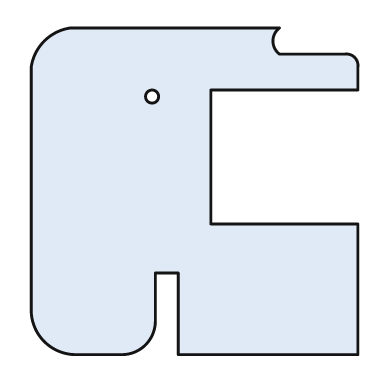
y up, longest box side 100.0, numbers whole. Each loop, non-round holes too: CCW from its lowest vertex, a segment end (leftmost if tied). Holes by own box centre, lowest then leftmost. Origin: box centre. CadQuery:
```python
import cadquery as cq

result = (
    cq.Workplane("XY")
    .moveTo(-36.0, -50.0)
    .lineTo(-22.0, -50.0)
    .threePointArc((-15.0, -47.0), (-12.0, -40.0))
    .lineTo(-12.0, -25.0)
    .lineTo(-5.0, -25.0)
    .lineTo(-5.0, -50.0)
    .lineTo(50.0, -50.0)
    .lineTo(50.0, -10.0)
    .lineTo(5.0, -10.0)
    .lineTo(5.0, 31.0)
    .lineTo(50.0, 31.0)
    .lineTo(50.0, 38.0)
    .threePointArc((49.0, 41.0), (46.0, 42.0))
    .lineTo(26.0, 42.0)
    .threePointArc((24.0, 46.0), (26.0, 50.0))
    .lineTo(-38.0, 50.0)
    .threePointArc((-46.0, 46.0), (-50.0, 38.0))
    .lineTo(-50.0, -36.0)
    .threePointArc((-46.0, -46.0), (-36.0, -50.0))
    .close()
    .moveTo(-13.0, 29.0)
    .circle(2.0)
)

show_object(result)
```